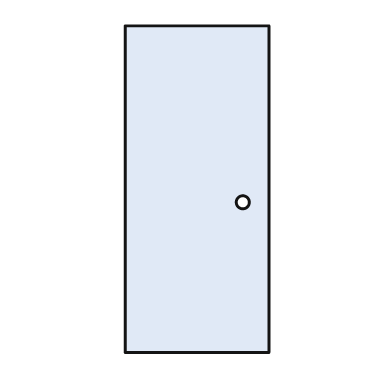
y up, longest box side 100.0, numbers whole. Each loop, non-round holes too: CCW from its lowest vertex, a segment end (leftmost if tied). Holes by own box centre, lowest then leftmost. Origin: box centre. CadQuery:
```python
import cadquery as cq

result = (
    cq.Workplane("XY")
    .moveTo(-22.0, -50.0)
    .lineTo(22.0, -50.0)
    .lineTo(22.0, 50.0)
    .lineTo(-22.0, 50.0)
    .close()
    .moveTo(14.0, -4.0)
    .circle(2.0)
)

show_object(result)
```